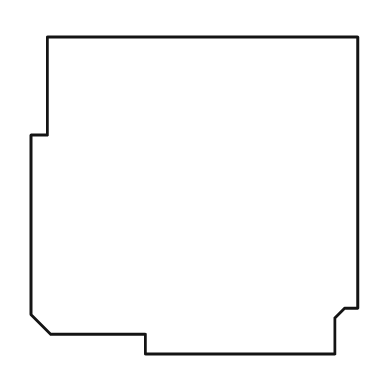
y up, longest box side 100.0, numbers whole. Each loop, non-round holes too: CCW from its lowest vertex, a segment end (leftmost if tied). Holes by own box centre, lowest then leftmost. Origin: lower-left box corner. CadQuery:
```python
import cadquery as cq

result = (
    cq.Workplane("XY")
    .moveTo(35.0, 0.0)
    .lineTo(93.0, 0.0)
    .lineTo(93.0, 11.0)
    .lineTo(96.0, 14.0)
    .lineTo(100.0, 14.0)
    .lineTo(100.0, 97.0)
    .lineTo(5.0, 97.0)
    .lineTo(5.0, 67.0)
    .lineTo(0.0, 67.0)
    .lineTo(0.0, 12.0)
    .lineTo(6.0, 6.0)
    .lineTo(35.0, 6.0)
    .close()
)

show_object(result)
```